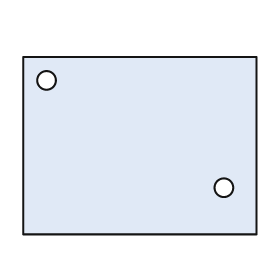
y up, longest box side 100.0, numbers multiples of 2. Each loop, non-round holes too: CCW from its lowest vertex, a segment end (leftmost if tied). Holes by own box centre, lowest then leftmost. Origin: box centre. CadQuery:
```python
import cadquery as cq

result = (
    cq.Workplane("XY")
    .moveTo(-50.0, -38.0)
    .lineTo(50.0, -38.0)
    .lineTo(50.0, 38.0)
    .lineTo(-50.0, 38.0)
    .close()
    .moveTo(36.0, -18.0)
    .circle(4.0)
    .moveTo(-40.0, 28.0)
    .circle(4.0)
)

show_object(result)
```